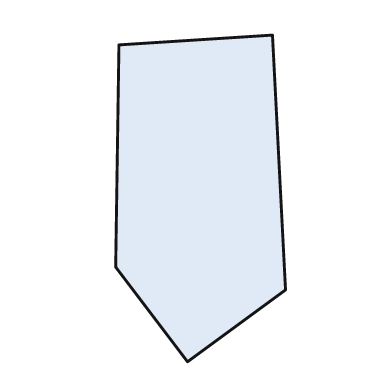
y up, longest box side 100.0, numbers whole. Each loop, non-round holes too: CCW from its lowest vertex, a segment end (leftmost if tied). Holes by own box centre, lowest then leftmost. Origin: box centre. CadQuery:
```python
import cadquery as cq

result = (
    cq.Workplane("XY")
    .moveTo(-4.0, -50.0)
    .lineTo(26.0, -28.0)
    .lineTo(22.0, 50.0)
    .lineTo(-25.0, 47.0)
    .lineTo(-26.0, -21.0)
    .close()
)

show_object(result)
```